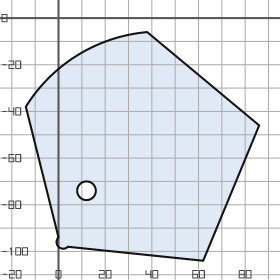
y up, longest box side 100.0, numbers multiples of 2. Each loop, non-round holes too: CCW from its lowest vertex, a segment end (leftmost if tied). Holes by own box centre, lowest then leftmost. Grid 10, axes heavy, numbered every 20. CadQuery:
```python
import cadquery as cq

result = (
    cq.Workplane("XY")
    .moveTo(62.0, -104.0)
    .lineTo(86.0, -46.0)
    .lineTo(38.0, -6.0)
    .threePointArc((8.0, -16.0), (-14.0, -38.0))
    .lineTo(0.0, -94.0)
    .threePointArc((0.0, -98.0), (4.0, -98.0))
    .close()
    .moveTo(12.0, -74.0)
    .circle(4.0)
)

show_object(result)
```